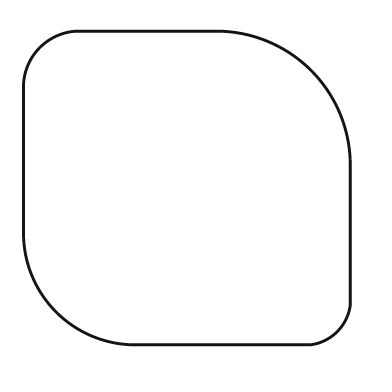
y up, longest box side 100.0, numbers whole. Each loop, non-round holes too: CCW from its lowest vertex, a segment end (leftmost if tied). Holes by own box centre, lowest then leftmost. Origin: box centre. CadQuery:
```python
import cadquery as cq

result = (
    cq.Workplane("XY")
    .moveTo(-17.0, -48.0)
    .lineTo(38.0, -48.0)
    .threePointArc((46.0, -44.0), (50.0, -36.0))
    .lineTo(50.0, 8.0)
    .threePointArc((38.0, 36.0), (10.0, 48.0))
    .lineTo(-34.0, 48.0)
    .threePointArc((-45.0, 43.0), (-50.0, 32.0))
    .lineTo(-50.0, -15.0)
    .threePointArc((-40.0, -38.0), (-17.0, -48.0))
    .close()
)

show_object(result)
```